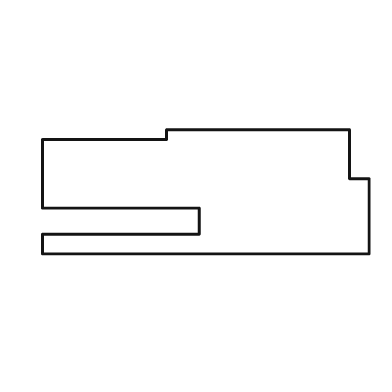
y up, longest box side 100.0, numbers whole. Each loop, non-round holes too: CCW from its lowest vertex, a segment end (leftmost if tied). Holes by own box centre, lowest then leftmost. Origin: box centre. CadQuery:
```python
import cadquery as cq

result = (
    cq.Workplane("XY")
    .moveTo(-50.0, -19.0)
    .lineTo(50.0, -19.0)
    .lineTo(50.0, 4.0)
    .lineTo(44.0, 4.0)
    .lineTo(44.0, 19.0)
    .lineTo(-12.0, 19.0)
    .lineTo(-12.0, 16.0)
    .lineTo(-50.0, 16.0)
    .lineTo(-50.0, -5.0)
    .lineTo(-2.0, -5.0)
    .lineTo(-2.0, -13.0)
    .lineTo(-50.0, -13.0)
    .close()
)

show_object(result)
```